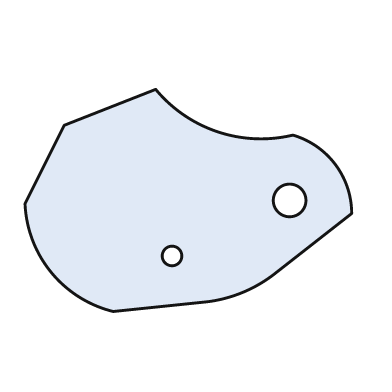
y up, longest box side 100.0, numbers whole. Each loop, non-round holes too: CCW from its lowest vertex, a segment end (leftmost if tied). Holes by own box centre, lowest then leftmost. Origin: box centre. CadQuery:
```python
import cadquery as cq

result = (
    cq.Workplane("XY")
    .moveTo(-23.0, -34.0)
    .lineTo(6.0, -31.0)
    .threePointArc((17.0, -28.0), (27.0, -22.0))
    .lineTo(50.0, -4.0)
    .threePointArc((45.0, 11.0), (32.0, 20.0))
    .threePointArc((9.0, 21.0), (-10.0, 34.0))
    .lineTo(-38.0, 23.0)
    .lineTo(-50.0, -1.0)
    .threePointArc((-42.0, -22.0), (-23.0, -34.0))
    .close()
    .moveTo(-5.0, -17.0)
    .circle(3.0)
    .moveTo(31.0, 0.0)
    .circle(5.0)
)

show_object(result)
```